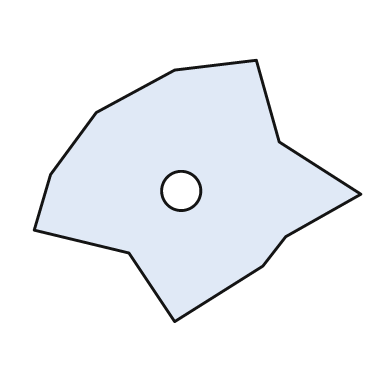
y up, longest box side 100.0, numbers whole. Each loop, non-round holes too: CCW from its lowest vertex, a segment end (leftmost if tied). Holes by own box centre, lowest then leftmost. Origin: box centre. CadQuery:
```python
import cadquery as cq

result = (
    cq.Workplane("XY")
    .moveTo(-7.0, -40.0)
    .lineTo(20.0, -23.0)
    .lineTo(27.0, -14.0)
    .lineTo(50.0, -1.0)
    .lineTo(25.0, 15.0)
    .lineTo(18.0, 40.0)
    .lineTo(-7.0, 37.0)
    .lineTo(-31.0, 24.0)
    .lineTo(-45.0, 5.0)
    .lineTo(-50.0, -12.0)
    .lineTo(-21.0, -19.0)
    .close()
    .moveTo(-5.0, 0.0)
    .circle(6.0)
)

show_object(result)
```